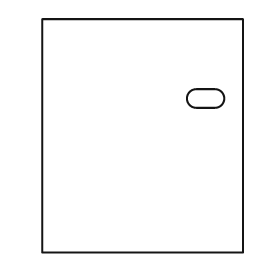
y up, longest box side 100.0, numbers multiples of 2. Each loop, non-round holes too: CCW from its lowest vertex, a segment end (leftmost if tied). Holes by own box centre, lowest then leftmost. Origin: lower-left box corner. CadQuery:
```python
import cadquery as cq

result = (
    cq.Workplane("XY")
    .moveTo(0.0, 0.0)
    .lineTo(86.0, 0.0)
    .lineTo(86.0, 100.0)
    .lineTo(0.0, 100.0)
    .close()
    .moveTo(66.0, 62.0)
    .lineTo(74.0, 62.0)
    .threePointArc((78.0, 66.0), (74.0, 70.0))
    .lineTo(66.0, 70.0)
    .threePointArc((62.0, 66.0), (66.0, 62.0))
    .close()
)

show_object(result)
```